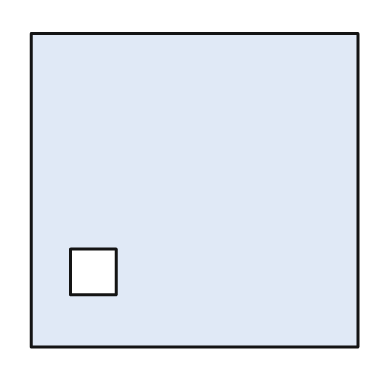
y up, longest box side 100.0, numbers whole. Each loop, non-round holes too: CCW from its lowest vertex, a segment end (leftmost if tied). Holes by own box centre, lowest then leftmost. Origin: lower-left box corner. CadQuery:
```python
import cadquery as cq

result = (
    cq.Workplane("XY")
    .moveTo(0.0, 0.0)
    .lineTo(100.0, 0.0)
    .lineTo(100.0, 96.0)
    .lineTo(0.0, 96.0)
    .close()
    .moveTo(12.0, 16.0)
    .lineTo(26.0, 16.0)
    .lineTo(26.0, 30.0)
    .lineTo(12.0, 30.0)
    .close()
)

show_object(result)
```